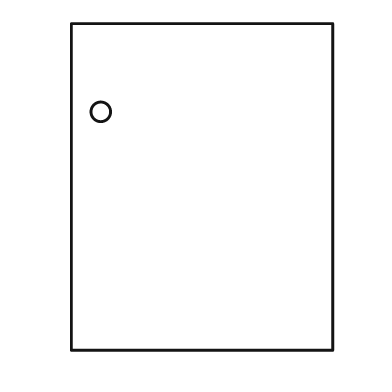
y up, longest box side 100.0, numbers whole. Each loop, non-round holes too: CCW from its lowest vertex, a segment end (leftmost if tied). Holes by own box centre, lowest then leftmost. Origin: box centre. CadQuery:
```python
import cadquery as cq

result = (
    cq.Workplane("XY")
    .moveTo(-40.0, -50.0)
    .lineTo(40.0, -50.0)
    .lineTo(40.0, 50.0)
    .lineTo(-40.0, 50.0)
    .close()
    .moveTo(-31.0, 23.0)
    .circle(3.0)
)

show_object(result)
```